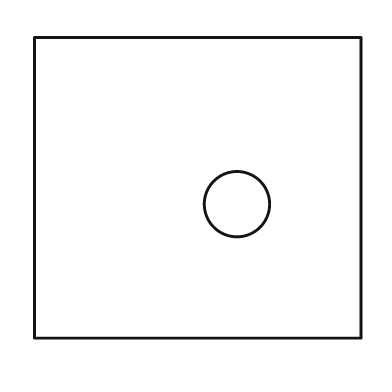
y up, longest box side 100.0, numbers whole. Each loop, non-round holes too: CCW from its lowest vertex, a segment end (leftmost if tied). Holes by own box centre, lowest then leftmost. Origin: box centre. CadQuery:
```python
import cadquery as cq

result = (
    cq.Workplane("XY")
    .moveTo(-50.0, -46.0)
    .lineTo(50.0, -46.0)
    .lineTo(50.0, 46.0)
    .lineTo(-50.0, 46.0)
    .close()
    .moveTo(12.0, -5.0)
    .circle(10.0)
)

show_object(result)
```